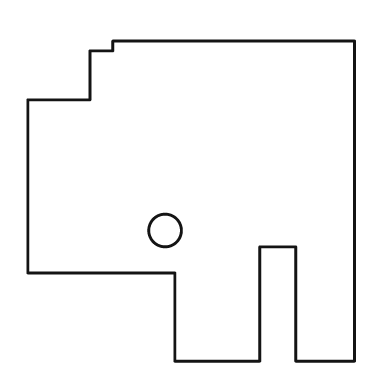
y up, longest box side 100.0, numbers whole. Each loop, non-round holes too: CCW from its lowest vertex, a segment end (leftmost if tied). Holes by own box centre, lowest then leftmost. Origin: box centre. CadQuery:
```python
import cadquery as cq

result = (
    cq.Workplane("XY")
    .moveTo(-5.0, -49.0)
    .lineTo(21.0, -49.0)
    .lineTo(21.0, -14.0)
    .lineTo(32.0, -14.0)
    .lineTo(32.0, -49.0)
    .lineTo(50.0, -49.0)
    .lineTo(50.0, 49.0)
    .lineTo(-24.0, 49.0)
    .lineTo(-24.0, 46.0)
    .lineTo(-31.0, 46.0)
    .lineTo(-31.0, 31.0)
    .lineTo(-50.0, 31.0)
    .lineTo(-50.0, -22.0)
    .lineTo(-5.0, -22.0)
    .close()
    .moveTo(-8.0, -9.0)
    .circle(5.0)
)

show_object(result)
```